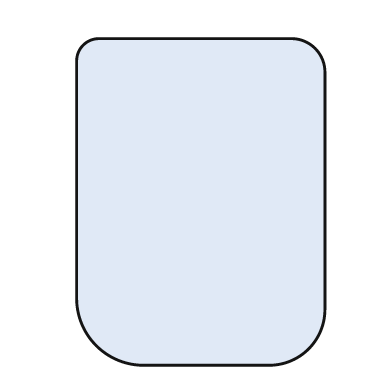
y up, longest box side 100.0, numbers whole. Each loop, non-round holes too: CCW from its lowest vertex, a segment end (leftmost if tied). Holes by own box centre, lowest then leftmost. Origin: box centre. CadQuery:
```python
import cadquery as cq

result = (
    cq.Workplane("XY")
    .moveTo(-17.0, -50.0)
    .lineTo(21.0, -50.0)
    .threePointArc((33.0, -45.0), (38.0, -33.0))
    .lineTo(38.0, 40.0)
    .threePointArc((35.0, 47.0), (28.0, 50.0))
    .lineTo(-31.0, 50.0)
    .threePointArc((-36.0, 48.0), (-38.0, 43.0))
    .lineTo(-38.0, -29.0)
    .threePointArc((-32.0, -44.0), (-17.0, -50.0))
    .close()
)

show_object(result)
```